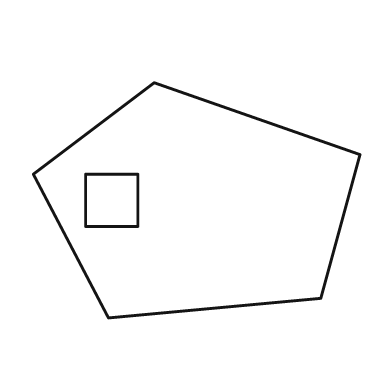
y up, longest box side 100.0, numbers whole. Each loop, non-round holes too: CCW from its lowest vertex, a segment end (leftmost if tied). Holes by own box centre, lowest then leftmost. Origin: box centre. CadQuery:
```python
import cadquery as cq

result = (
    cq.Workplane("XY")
    .moveTo(-27.0, -36.0)
    .lineTo(38.0, -30.0)
    .lineTo(50.0, 14.0)
    .lineTo(-13.0, 36.0)
    .lineTo(-50.0, 8.0)
    .close()
    .moveTo(-34.0, -8.0)
    .lineTo(-18.0, -8.0)
    .lineTo(-18.0, 8.0)
    .lineTo(-34.0, 8.0)
    .close()
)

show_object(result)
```